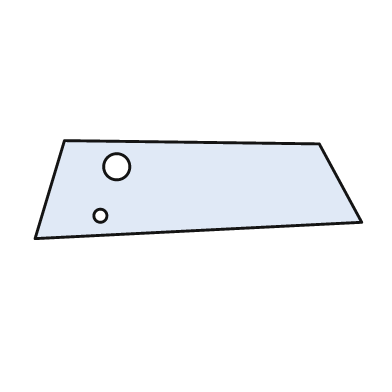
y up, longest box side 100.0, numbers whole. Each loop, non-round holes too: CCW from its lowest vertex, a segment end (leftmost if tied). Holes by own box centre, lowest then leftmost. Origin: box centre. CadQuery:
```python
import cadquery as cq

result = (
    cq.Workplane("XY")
    .moveTo(-50.0, -15.0)
    .lineTo(50.0, -10.0)
    .lineTo(37.0, 14.0)
    .lineTo(-41.0, 15.0)
    .close()
    .moveTo(-30.0, -8.0)
    .circle(2.0)
    .moveTo(-25.0, 7.0)
    .circle(4.0)
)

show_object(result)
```